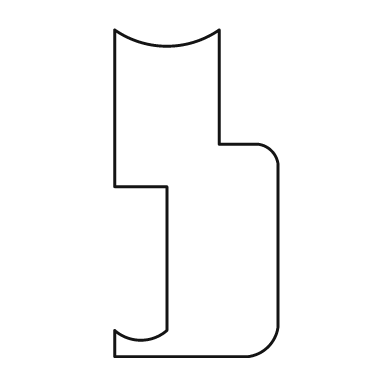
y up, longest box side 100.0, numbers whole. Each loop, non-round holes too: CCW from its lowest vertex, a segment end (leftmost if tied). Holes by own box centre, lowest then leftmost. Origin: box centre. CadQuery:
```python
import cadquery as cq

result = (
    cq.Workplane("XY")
    .moveTo(-25.0, -50.0)
    .lineTo(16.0, -50.0)
    .threePointArc((22.0, -47.0), (25.0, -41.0))
    .lineTo(25.0, 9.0)
    .threePointArc((23.0, 13.0), (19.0, 15.0))
    .lineTo(7.0, 15.0)
    .lineTo(7.0, 50.0)
    .threePointArc((-9.0, 45.0), (-25.0, 50.0))
    .lineTo(-25.0, 2.0)
    .lineTo(-9.0, 2.0)
    .lineTo(-9.0, -42.0)
    .threePointArc((-17.0, -45.0), (-25.0, -42.0))
    .close()
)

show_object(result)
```